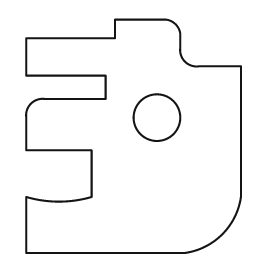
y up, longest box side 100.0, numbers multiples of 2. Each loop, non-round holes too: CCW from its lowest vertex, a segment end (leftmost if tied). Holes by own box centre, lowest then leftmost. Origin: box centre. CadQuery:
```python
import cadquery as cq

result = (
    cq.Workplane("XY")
    .moveTo(-46.0, -50.0)
    .lineTo(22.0, -50.0)
    .threePointArc((38.0, -42.0), (46.0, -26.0))
    .lineTo(46.0, 30.0)
    .lineTo(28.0, 30.0)
    .threePointArc((22.0, 32.0), (20.0, 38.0))
    .lineTo(20.0, 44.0)
    .threePointArc((18.0, 48.0), (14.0, 50.0))
    .lineTo(-8.0, 50.0)
    .lineTo(-8.0, 42.0)
    .lineTo(-46.0, 42.0)
    .lineTo(-46.0, 26.0)
    .lineTo(-12.0, 26.0)
    .lineTo(-12.0, 16.0)
    .lineTo(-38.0, 16.0)
    .threePointArc((-44.0, 14.0), (-46.0, 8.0))
    .lineTo(-46.0, -6.0)
    .lineTo(-18.0, -6.0)
    .lineTo(-18.0, -26.0)
    .threePointArc((-32.0, -28.0), (-46.0, -26.0))
    .close()
    .moveTo(10.0, 8.0)
    .circle(10.0)
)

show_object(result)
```